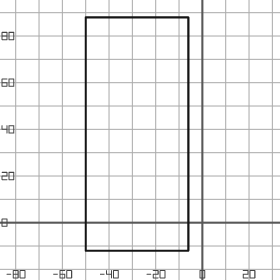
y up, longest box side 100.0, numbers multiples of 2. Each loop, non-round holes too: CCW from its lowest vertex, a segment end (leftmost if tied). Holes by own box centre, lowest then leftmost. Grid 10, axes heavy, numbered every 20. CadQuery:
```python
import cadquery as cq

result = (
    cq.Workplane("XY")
    .moveTo(-50.0, -12.0)
    .lineTo(-6.0, -12.0)
    .lineTo(-6.0, 88.0)
    .lineTo(-50.0, 88.0)
    .close()
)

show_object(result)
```